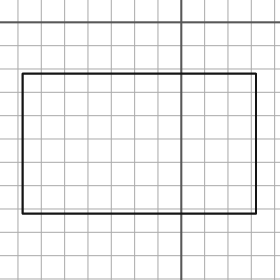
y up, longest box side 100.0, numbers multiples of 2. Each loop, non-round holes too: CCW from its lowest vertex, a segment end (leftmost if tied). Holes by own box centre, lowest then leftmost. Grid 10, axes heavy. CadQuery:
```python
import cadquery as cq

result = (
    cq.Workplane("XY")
    .moveTo(-68.0, -82.0)
    .lineTo(32.0, -82.0)
    .lineTo(32.0, -22.0)
    .lineTo(-68.0, -22.0)
    .close()
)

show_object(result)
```